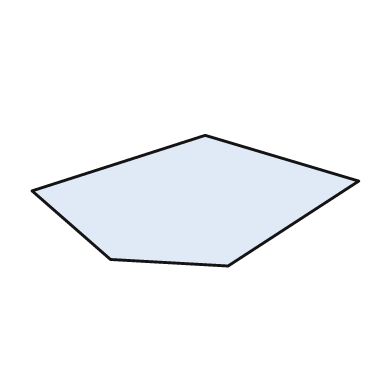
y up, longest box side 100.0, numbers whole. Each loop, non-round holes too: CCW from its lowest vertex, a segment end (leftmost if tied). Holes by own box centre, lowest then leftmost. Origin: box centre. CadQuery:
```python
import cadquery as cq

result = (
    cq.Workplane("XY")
    .moveTo(10.0, -20.0)
    .lineTo(50.0, 6.0)
    .lineTo(3.0, 20.0)
    .lineTo(-50.0, 3.0)
    .lineTo(-26.0, -18.0)
    .close()
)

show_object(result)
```